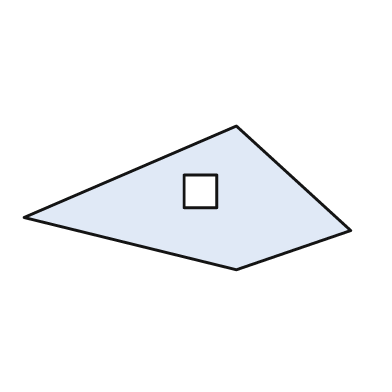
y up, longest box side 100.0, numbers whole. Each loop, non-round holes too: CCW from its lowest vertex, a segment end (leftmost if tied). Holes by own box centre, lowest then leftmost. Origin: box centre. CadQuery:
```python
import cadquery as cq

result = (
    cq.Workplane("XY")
    .moveTo(15.0, -22.0)
    .lineTo(50.0, -10.0)
    .lineTo(15.0, 22.0)
    .lineTo(-50.0, -6.0)
    .close()
    .moveTo(-1.0, -3.0)
    .lineTo(9.0, -3.0)
    .lineTo(9.0, 7.0)
    .lineTo(-1.0, 7.0)
    .close()
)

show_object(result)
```